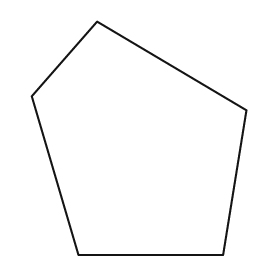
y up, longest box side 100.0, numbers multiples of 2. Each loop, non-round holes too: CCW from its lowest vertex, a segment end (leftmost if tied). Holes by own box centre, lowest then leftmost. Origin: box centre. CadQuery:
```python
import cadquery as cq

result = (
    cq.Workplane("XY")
    .moveTo(-26.0, -50.0)
    .lineTo(36.0, -50.0)
    .lineTo(46.0, 12.0)
    .lineTo(-18.0, 50.0)
    .lineTo(-46.0, 18.0)
    .close()
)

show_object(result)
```